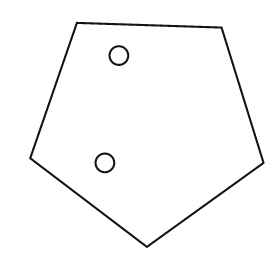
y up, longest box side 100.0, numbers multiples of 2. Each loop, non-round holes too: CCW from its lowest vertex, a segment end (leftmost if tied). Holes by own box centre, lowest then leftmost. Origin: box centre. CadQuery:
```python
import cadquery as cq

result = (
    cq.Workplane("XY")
    .moveTo(0.0, -48.0)
    .lineTo(50.0, -12.0)
    .lineTo(32.0, 46.0)
    .lineTo(-30.0, 48.0)
    .lineTo(-50.0, -10.0)
    .close()
    .moveTo(-18.0, -12.0)
    .circle(4.0)
    .moveTo(-12.0, 34.0)
    .circle(4.0)
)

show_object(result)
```